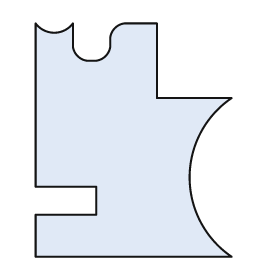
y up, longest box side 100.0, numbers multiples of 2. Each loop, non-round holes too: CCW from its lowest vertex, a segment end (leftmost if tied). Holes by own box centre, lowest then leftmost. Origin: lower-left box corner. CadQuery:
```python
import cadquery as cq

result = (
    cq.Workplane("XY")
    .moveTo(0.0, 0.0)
    .lineTo(84.0, 0.0)
    .threePointArc((66.0, 34.0), (84.0, 68.0))
    .lineTo(52.0, 68.0)
    .lineTo(52.0, 100.0)
    .lineTo(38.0, 100.0)
    .threePointArc((34.0, 98.0), (32.0, 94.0))
    .lineTo(32.0, 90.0)
    .threePointArc((30.0, 86.0), (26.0, 84.0))
    .lineTo(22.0, 84.0)
    .threePointArc((18.0, 86.0), (16.0, 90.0))
    .lineTo(16.0, 100.0)
    .threePointArc((8.0, 96.0), (0.0, 100.0))
    .lineTo(0.0, 30.0)
    .lineTo(26.0, 30.0)
    .lineTo(26.0, 18.0)
    .lineTo(0.0, 18.0)
    .close()
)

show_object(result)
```